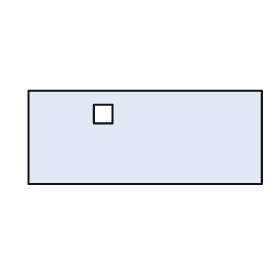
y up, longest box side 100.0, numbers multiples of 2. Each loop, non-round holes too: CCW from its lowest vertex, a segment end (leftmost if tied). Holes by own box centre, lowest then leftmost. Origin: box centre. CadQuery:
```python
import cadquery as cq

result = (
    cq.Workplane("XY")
    .moveTo(-50.0, -20.0)
    .lineTo(50.0, -20.0)
    .lineTo(50.0, 20.0)
    .lineTo(-50.0, 20.0)
    .close()
    .moveTo(-22.0, 6.0)
    .lineTo(-14.0, 6.0)
    .lineTo(-14.0, 14.0)
    .lineTo(-22.0, 14.0)
    .close()
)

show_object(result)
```